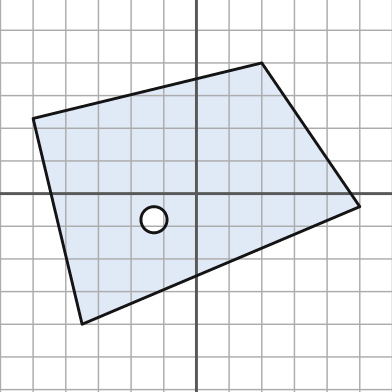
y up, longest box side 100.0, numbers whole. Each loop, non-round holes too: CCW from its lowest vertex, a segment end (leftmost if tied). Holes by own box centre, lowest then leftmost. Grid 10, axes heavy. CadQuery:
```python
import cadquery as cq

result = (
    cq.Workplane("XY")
    .moveTo(-35.0, -40.0)
    .lineTo(50.0, -4.0)
    .lineTo(20.0, 40.0)
    .lineTo(-50.0, 23.0)
    .close()
    .moveTo(-13.0, -8.0)
    .circle(4.0)
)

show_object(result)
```